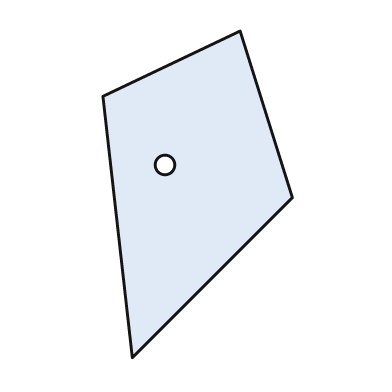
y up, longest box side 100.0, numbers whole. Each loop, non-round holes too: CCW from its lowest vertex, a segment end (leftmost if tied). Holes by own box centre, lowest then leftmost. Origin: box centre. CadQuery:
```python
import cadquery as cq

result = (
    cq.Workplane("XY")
    .moveTo(-20.0, -50.0)
    .lineTo(29.0, -1.0)
    .lineTo(13.0, 50.0)
    .lineTo(-29.0, 30.0)
    .close()
    .moveTo(-10.0, 9.0)
    .circle(3.0)
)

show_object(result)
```